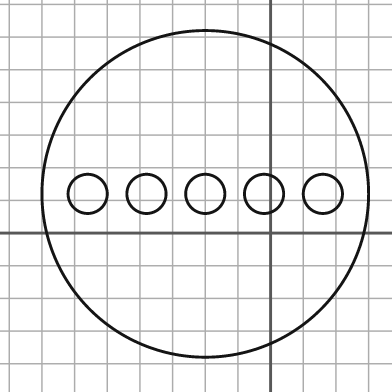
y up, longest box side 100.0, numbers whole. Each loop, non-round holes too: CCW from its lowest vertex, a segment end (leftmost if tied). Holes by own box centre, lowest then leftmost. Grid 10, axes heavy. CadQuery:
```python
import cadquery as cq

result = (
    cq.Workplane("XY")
    .moveTo(-20.0, 12.0)
    .circle(50.0)
    .moveTo(-56.0, 12.0)
    .circle(6.0)
    .moveTo(-38.0, 12.0)
    .circle(6.0)
    .moveTo(-20.0, 12.0)
    .circle(6.0)
    .moveTo(-2.0, 12.0)
    .circle(6.0)
    .moveTo(16.0, 12.0)
    .circle(6.0)
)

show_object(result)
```